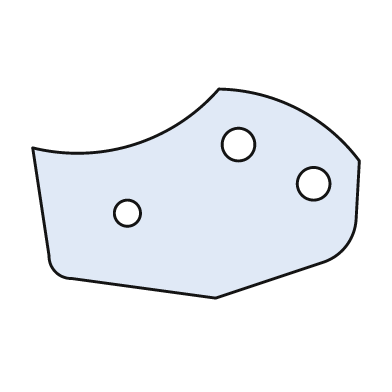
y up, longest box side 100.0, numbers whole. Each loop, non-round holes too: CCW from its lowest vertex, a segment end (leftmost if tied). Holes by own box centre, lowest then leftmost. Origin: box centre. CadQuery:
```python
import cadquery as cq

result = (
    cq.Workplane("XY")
    .moveTo(6.0, -32.0)
    .lineTo(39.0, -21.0)
    .threePointArc((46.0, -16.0), (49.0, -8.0))
    .lineTo(50.0, 10.0)
    .threePointArc((31.0, 26.0), (7.0, 32.0))
    .threePointArc((-19.0, 15.0), (-50.0, 14.0))
    .lineTo(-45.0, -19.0)
    .threePointArc((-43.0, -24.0), (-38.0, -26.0))
    .close()
    .moveTo(-21.0, -6.0)
    .circle(4.0)
    .moveTo(36.0, 3.0)
    .circle(5.0)
    .moveTo(13.0, 15.0)
    .circle(5.0)
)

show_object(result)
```